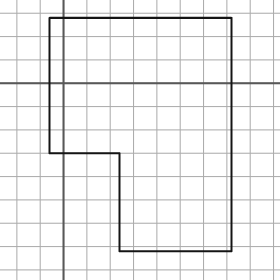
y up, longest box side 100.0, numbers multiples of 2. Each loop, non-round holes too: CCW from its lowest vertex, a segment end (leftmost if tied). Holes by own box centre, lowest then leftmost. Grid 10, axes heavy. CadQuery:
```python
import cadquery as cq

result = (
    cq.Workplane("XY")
    .moveTo(24.0, -72.0)
    .lineTo(72.0, -72.0)
    .lineTo(72.0, 28.0)
    .lineTo(-6.0, 28.0)
    .lineTo(-6.0, -30.0)
    .lineTo(24.0, -30.0)
    .close()
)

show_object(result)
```